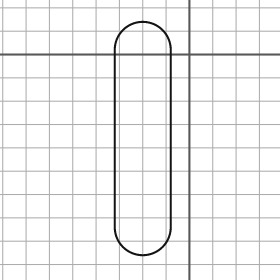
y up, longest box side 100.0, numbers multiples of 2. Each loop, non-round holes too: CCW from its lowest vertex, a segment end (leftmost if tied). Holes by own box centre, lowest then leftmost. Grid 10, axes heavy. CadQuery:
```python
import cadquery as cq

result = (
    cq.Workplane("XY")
    .moveTo(-32.0, -74.0)
    .threePointArc((-20.0, -86.0), (-8.0, -74.0))
    .lineTo(-8.0, 2.0)
    .threePointArc((-20.0, 14.0), (-32.0, 2.0))
    .close()
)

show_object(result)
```